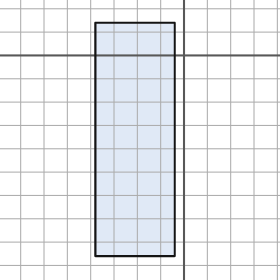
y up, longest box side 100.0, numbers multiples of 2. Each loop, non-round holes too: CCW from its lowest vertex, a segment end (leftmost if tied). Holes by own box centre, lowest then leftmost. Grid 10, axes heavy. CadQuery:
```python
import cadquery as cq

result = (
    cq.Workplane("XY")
    .moveTo(-38.0, -86.0)
    .lineTo(-4.0, -86.0)
    .lineTo(-4.0, 14.0)
    .lineTo(-38.0, 14.0)
    .close()
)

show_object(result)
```